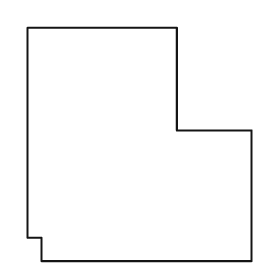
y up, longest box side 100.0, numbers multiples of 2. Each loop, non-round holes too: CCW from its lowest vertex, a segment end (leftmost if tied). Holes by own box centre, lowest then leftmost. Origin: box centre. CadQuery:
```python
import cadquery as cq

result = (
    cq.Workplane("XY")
    .moveTo(-42.0, -50.0)
    .lineTo(48.0, -50.0)
    .lineTo(48.0, 6.0)
    .lineTo(16.0, 6.0)
    .lineTo(16.0, 50.0)
    .lineTo(-48.0, 50.0)
    .lineTo(-48.0, -40.0)
    .lineTo(-42.0, -40.0)
    .close()
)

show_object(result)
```